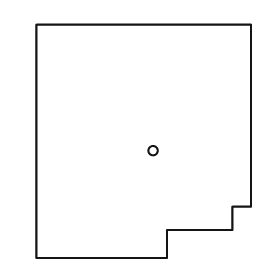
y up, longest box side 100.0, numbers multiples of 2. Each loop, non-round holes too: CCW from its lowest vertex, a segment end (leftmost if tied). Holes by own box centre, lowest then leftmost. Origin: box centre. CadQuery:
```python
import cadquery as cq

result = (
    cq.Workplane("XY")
    .moveTo(-46.0, -50.0)
    .lineTo(10.0, -50.0)
    .lineTo(10.0, -38.0)
    .lineTo(38.0, -38.0)
    .lineTo(38.0, -28.0)
    .lineTo(46.0, -28.0)
    .lineTo(46.0, 50.0)
    .lineTo(-46.0, 50.0)
    .close()
    .moveTo(4.0, -4.0)
    .circle(2.0)
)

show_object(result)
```